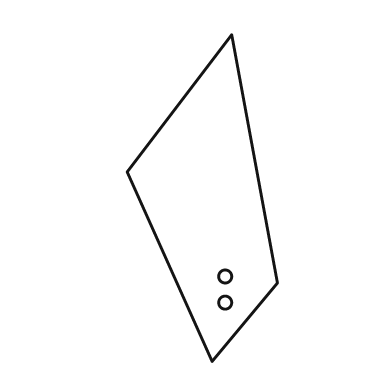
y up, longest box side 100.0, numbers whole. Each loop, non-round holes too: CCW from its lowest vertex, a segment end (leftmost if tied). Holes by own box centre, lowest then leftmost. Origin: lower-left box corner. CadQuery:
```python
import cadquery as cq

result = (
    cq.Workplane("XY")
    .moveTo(26.0, 0.0)
    .lineTo(46.0, 24.0)
    .lineTo(32.0, 100.0)
    .lineTo(0.0, 58.0)
    .close()
    .moveTo(30.0, 18.0)
    .circle(2.0)
    .moveTo(30.0, 26.0)
    .circle(2.0)
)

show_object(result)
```